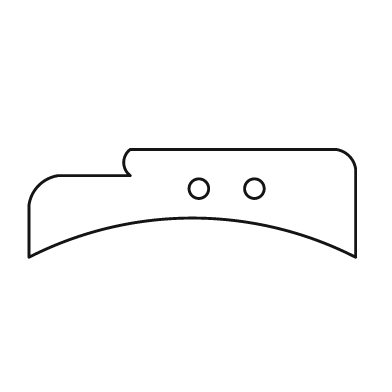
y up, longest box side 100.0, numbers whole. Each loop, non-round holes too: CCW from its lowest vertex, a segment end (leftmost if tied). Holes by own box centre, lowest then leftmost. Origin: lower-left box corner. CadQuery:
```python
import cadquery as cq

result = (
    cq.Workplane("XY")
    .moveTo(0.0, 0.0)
    .threePointArc((50.0, 12.0), (100.0, 0.0))
    .lineTo(100.0, 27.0)
    .threePointArc((98.0, 31.0), (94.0, 33.0))
    .lineTo(31.0, 33.0)
    .threePointArc((29.0, 29.0), (31.0, 25.0))
    .lineTo(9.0, 25.0)
    .threePointArc((3.0, 22.0), (0.0, 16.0))
    .close()
    .moveTo(52.0, 21.0)
    .circle(3.0)
    .moveTo(69.0, 21.0)
    .circle(3.0)
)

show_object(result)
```